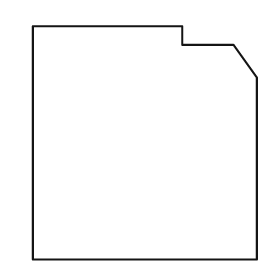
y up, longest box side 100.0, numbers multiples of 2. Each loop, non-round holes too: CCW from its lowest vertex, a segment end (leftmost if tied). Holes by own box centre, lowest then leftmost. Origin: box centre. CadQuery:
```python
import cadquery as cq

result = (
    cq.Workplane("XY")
    .moveTo(-48.0, -50.0)
    .lineTo(48.0, -50.0)
    .lineTo(48.0, 28.0)
    .lineTo(38.0, 42.0)
    .lineTo(16.0, 42.0)
    .lineTo(16.0, 50.0)
    .lineTo(-48.0, 50.0)
    .close()
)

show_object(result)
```